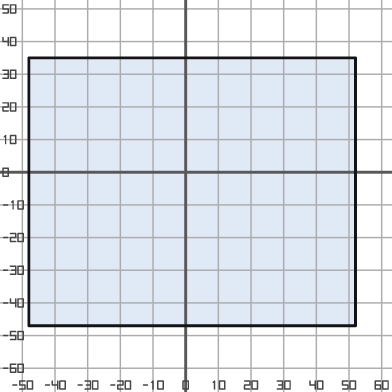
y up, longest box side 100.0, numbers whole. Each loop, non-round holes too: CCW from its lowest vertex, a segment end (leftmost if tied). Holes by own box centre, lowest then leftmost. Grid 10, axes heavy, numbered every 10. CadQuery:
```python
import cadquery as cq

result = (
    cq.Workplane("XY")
    .moveTo(-48.0, -47.0)
    .lineTo(52.0, -47.0)
    .lineTo(52.0, 35.0)
    .lineTo(-48.0, 35.0)
    .close()
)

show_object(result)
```